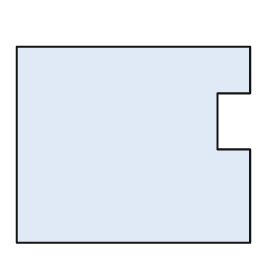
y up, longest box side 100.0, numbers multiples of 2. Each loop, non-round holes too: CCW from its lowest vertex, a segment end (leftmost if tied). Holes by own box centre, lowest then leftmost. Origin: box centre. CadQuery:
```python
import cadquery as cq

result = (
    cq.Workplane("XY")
    .moveTo(-50.0, -42.0)
    .lineTo(50.0, -42.0)
    .lineTo(50.0, -2.0)
    .lineTo(36.0, -2.0)
    .lineTo(36.0, 22.0)
    .lineTo(50.0, 22.0)
    .lineTo(50.0, 42.0)
    .lineTo(-50.0, 42.0)
    .close()
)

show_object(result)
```